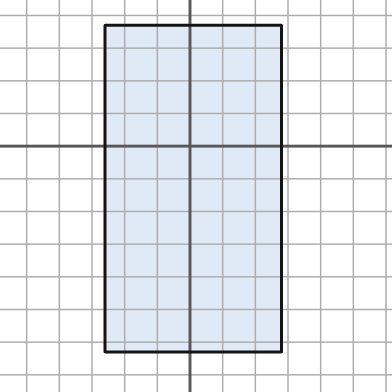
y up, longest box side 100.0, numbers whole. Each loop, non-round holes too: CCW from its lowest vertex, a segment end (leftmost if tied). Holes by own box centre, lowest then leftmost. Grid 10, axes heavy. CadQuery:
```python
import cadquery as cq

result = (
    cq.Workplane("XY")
    .moveTo(-26.0, -63.0)
    .lineTo(28.0, -63.0)
    .lineTo(28.0, 37.0)
    .lineTo(-26.0, 37.0)
    .close()
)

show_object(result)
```